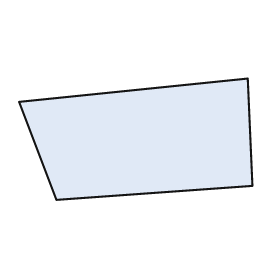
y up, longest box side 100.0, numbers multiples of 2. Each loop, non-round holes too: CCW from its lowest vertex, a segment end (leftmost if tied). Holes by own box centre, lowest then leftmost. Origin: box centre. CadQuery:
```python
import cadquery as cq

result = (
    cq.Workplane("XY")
    .moveTo(-34.0, -26.0)
    .lineTo(50.0, -20.0)
    .lineTo(48.0, 26.0)
    .lineTo(-50.0, 16.0)
    .close()
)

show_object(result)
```